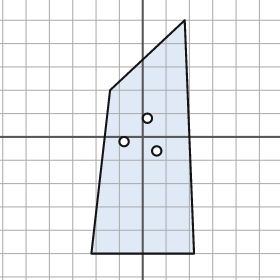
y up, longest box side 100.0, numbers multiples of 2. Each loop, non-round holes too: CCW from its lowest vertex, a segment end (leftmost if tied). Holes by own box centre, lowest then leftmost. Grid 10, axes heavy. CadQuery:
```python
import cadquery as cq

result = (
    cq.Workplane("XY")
    .moveTo(-22.0, -50.0)
    .lineTo(22.0, -50.0)
    .lineTo(18.0, 50.0)
    .lineTo(-14.0, 20.0)
    .close()
    .moveTo(6.0, -6.0)
    .circle(2.0)
    .moveTo(-8.0, -2.0)
    .circle(2.0)
    .moveTo(2.0, 8.0)
    .circle(2.0)
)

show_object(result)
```